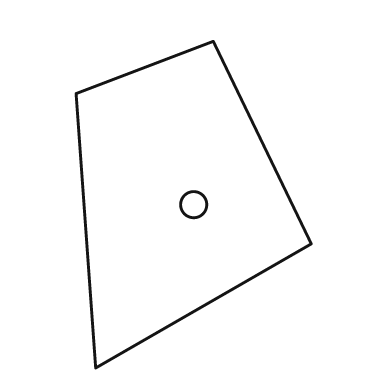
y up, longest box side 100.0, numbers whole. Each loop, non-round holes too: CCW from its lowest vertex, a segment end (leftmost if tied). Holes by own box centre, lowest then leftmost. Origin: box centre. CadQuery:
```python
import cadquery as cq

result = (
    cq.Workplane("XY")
    .moveTo(-30.0, -50.0)
    .lineTo(36.0, -12.0)
    .lineTo(6.0, 50.0)
    .lineTo(-36.0, 34.0)
    .close()
    .moveTo(0.0, 0.0)
    .circle(4.0)
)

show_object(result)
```